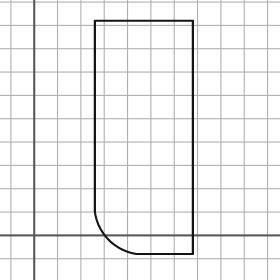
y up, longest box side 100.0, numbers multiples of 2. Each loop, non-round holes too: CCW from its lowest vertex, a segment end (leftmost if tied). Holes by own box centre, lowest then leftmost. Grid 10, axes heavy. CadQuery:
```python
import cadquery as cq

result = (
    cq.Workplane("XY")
    .moveTo(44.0, -8.0)
    .lineTo(68.0, -8.0)
    .lineTo(68.0, 92.0)
    .lineTo(26.0, 92.0)
    .lineTo(26.0, 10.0)
    .threePointArc((32.0, -2.0), (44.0, -8.0))
    .close()
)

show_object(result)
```